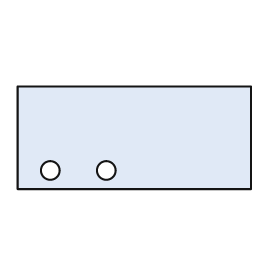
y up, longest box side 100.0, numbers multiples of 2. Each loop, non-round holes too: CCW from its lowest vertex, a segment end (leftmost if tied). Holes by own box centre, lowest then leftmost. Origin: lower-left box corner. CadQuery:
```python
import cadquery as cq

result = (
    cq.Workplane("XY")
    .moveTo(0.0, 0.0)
    .lineTo(100.0, 0.0)
    .lineTo(100.0, 44.0)
    .lineTo(0.0, 44.0)
    .close()
    .moveTo(14.0, 8.0)
    .circle(4.0)
    .moveTo(38.0, 8.0)
    .circle(4.0)
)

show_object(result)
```